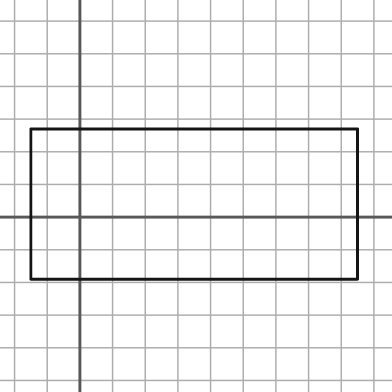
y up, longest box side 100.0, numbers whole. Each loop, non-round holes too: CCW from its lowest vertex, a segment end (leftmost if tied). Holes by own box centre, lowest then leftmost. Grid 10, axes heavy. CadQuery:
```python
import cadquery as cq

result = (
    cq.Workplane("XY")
    .moveTo(-15.0, -19.0)
    .lineTo(85.0, -19.0)
    .lineTo(85.0, 27.0)
    .lineTo(-15.0, 27.0)
    .close()
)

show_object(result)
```